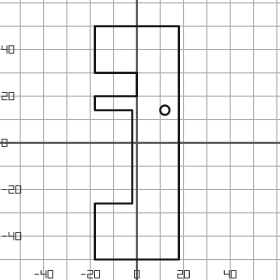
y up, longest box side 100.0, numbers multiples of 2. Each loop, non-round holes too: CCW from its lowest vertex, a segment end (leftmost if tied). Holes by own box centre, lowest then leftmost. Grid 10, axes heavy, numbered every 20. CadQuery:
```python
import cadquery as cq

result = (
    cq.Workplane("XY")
    .moveTo(-18.0, -50.0)
    .lineTo(18.0, -50.0)
    .lineTo(18.0, 50.0)
    .lineTo(-18.0, 50.0)
    .lineTo(-18.0, 30.0)
    .lineTo(0.0, 30.0)
    .lineTo(0.0, 20.0)
    .lineTo(-18.0, 20.0)
    .lineTo(-18.0, 14.0)
    .lineTo(-2.0, 14.0)
    .lineTo(-2.0, -26.0)
    .lineTo(-18.0, -26.0)
    .close()
    .moveTo(12.0, 14.0)
    .circle(2.0)
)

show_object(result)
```